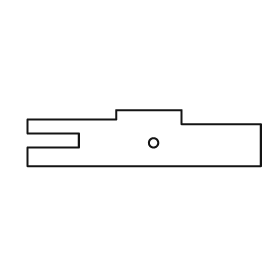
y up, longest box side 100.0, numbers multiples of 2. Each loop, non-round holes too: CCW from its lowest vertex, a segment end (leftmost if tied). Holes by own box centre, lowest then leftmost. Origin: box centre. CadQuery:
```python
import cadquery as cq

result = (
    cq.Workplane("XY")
    .moveTo(-50.0, -12.0)
    .lineTo(50.0, -12.0)
    .lineTo(50.0, 6.0)
    .lineTo(16.0, 6.0)
    .lineTo(16.0, 12.0)
    .lineTo(-12.0, 12.0)
    .lineTo(-12.0, 8.0)
    .lineTo(-50.0, 8.0)
    .lineTo(-50.0, 2.0)
    .lineTo(-28.0, 2.0)
    .lineTo(-28.0, -4.0)
    .lineTo(-50.0, -4.0)
    .close()
    .moveTo(4.0, -2.0)
    .circle(2.0)
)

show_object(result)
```